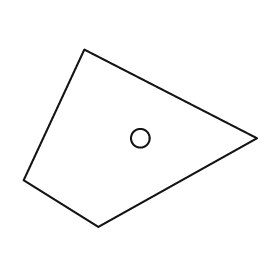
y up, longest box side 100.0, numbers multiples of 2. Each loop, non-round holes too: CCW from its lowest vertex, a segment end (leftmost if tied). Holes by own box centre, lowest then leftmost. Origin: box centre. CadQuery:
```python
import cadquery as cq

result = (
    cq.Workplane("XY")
    .moveTo(-18.0, -38.0)
    .lineTo(50.0, 0.0)
    .lineTo(-24.0, 38.0)
    .lineTo(-50.0, -18.0)
    .close()
    .moveTo(0.0, 0.0)
    .circle(4.0)
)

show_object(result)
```